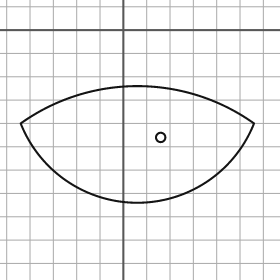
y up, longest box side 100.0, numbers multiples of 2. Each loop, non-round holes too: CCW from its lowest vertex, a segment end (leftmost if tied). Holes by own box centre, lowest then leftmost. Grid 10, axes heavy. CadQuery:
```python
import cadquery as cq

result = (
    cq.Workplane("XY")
    .moveTo(-44.0, -40.0)
    .threePointArc((6.0, -74.0), (56.0, -40.0))
    .threePointArc((6.0, -24.0), (-44.0, -40.0))
    .close()
    .moveTo(16.0, -46.0)
    .circle(2.0)
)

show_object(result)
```